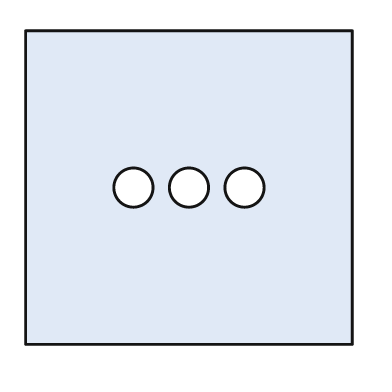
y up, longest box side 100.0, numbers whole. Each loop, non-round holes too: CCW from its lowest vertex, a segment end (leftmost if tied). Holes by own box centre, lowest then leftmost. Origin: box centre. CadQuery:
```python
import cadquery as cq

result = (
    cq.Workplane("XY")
    .moveTo(-50.0, -48.0)
    .lineTo(50.0, -48.0)
    .lineTo(50.0, 48.0)
    .lineTo(-50.0, 48.0)
    .close()
    .moveTo(-17.0, 0.0)
    .circle(6.0)
    .moveTo(0.0, 0.0)
    .circle(6.0)
    .moveTo(17.0, 0.0)
    .circle(6.0)
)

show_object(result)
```